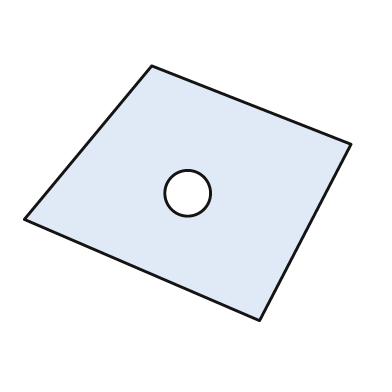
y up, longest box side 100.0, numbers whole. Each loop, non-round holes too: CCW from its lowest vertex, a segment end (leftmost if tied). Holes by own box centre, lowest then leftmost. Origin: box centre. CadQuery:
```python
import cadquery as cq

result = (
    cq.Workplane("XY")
    .moveTo(22.0, -39.0)
    .lineTo(50.0, 15.0)
    .lineTo(-11.0, 39.0)
    .lineTo(-50.0, -8.0)
    .close()
    .moveTo(0.0, 0.0)
    .circle(7.0)
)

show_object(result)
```